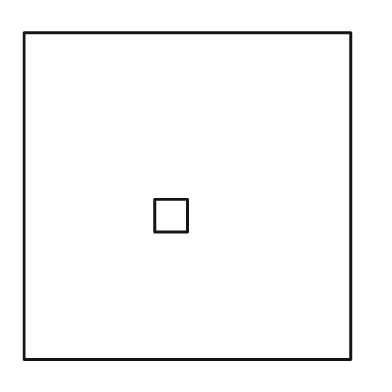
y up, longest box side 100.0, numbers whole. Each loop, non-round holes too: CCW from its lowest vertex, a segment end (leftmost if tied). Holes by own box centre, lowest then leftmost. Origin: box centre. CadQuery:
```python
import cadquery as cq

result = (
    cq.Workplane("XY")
    .moveTo(-50.0, -50.0)
    .lineTo(50.0, -50.0)
    .lineTo(50.0, 50.0)
    .lineTo(-50.0, 50.0)
    .close()
    .moveTo(-10.0, -11.0)
    .lineTo(0.0, -11.0)
    .lineTo(0.0, -1.0)
    .lineTo(-10.0, -1.0)
    .close()
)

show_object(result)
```